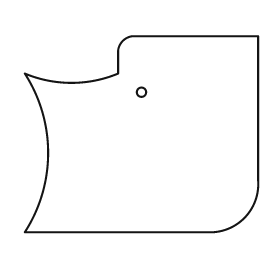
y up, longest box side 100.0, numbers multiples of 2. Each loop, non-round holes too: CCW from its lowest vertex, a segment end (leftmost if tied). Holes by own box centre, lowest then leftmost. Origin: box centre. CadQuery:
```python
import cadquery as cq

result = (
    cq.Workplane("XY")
    .moveTo(-50.0, -42.0)
    .lineTo(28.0, -42.0)
    .threePointArc((44.0, -36.0), (50.0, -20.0))
    .lineTo(50.0, 42.0)
    .lineTo(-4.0, 42.0)
    .threePointArc((-8.0, 40.0), (-10.0, 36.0))
    .lineTo(-10.0, 26.0)
    .threePointArc((-30.0, 22.0), (-50.0, 26.0))
    .threePointArc((-40.0, -8.0), (-50.0, -42.0))
    .close()
    .moveTo(0.0, 18.0)
    .circle(2.0)
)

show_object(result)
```